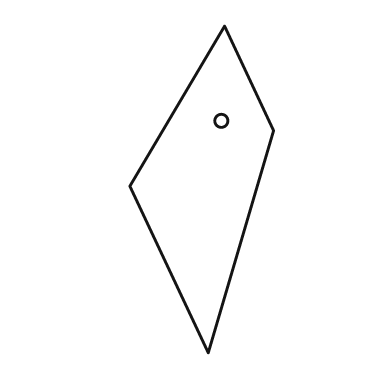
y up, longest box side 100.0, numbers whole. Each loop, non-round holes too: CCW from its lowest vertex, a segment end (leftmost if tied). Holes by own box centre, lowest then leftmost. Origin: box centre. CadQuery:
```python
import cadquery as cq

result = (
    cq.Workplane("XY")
    .moveTo(2.0, -50.0)
    .lineTo(22.0, 18.0)
    .lineTo(7.0, 50.0)
    .lineTo(-22.0, 1.0)
    .close()
    .moveTo(6.0, 21.0)
    .circle(2.0)
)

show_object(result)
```